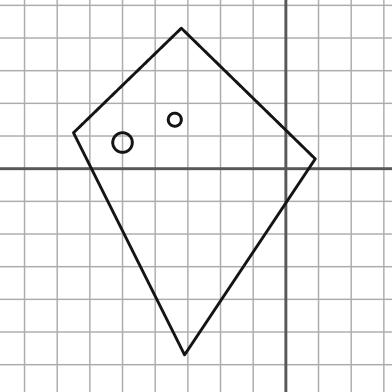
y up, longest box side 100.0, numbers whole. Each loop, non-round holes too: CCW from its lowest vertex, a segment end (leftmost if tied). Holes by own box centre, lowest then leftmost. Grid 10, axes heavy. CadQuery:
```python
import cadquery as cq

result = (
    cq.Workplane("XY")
    .moveTo(-31.0, -57.0)
    .lineTo(9.0, 3.0)
    .lineTo(-32.0, 43.0)
    .lineTo(-65.0, 11.0)
    .close()
    .moveTo(-50.0, 8.0)
    .circle(3.0)
    .moveTo(-34.0, 15.0)
    .circle(2.0)
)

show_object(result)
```